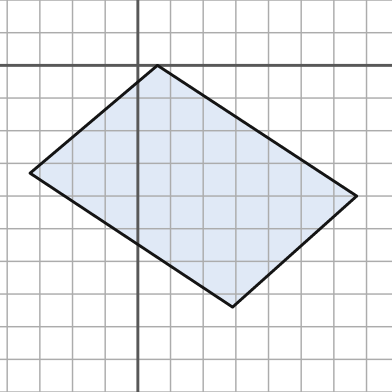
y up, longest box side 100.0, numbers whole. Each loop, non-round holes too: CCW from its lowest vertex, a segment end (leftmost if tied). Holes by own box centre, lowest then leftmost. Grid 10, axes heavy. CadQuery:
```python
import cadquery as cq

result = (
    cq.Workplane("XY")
    .moveTo(29.0, -74.0)
    .lineTo(67.0, -40.0)
    .lineTo(6.0, 0.0)
    .lineTo(-33.0, -33.0)
    .close()
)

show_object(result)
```